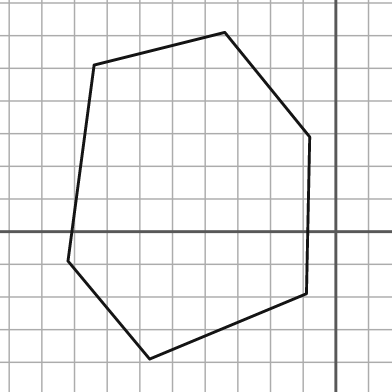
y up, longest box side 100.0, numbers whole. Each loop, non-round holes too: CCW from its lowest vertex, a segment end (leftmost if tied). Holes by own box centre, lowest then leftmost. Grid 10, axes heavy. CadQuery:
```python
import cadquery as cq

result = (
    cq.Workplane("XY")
    .moveTo(-57.0, -39.0)
    .lineTo(-9.0, -19.0)
    .lineTo(-8.0, 29.0)
    .lineTo(-34.0, 61.0)
    .lineTo(-74.0, 51.0)
    .lineTo(-82.0, -9.0)
    .close()
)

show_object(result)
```